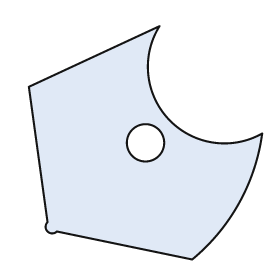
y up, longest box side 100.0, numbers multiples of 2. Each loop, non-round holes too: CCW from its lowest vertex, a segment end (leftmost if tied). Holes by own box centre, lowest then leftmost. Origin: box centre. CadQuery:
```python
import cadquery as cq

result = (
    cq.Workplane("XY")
    .moveTo(20.0, -50.0)
    .threePointArc((40.0, -26.0), (50.0, 4.0))
    .threePointArc((10.0, 10.0), (6.0, 50.0))
    .lineTo(-50.0, 24.0)
    .lineTo(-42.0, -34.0)
    .threePointArc((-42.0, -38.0), (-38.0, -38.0))
    .close()
    .moveTo(0.0, 0.0)
    .circle(8.0)
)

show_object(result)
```